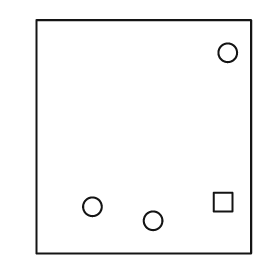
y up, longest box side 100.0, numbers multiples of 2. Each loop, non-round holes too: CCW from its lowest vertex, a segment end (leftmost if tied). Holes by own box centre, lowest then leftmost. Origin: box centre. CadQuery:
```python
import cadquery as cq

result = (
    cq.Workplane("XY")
    .moveTo(-46.0, -50.0)
    .lineTo(46.0, -50.0)
    .lineTo(46.0, 50.0)
    .lineTo(-46.0, 50.0)
    .close()
    .moveTo(4.0, -36.0)
    .circle(4.0)
    .moveTo(-22.0, -30.0)
    .circle(4.0)
    .moveTo(30.0, -32.0)
    .lineTo(38.0, -32.0)
    .lineTo(38.0, -24.0)
    .lineTo(30.0, -24.0)
    .close()
    .moveTo(36.0, 36.0)
    .circle(4.0)
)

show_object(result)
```